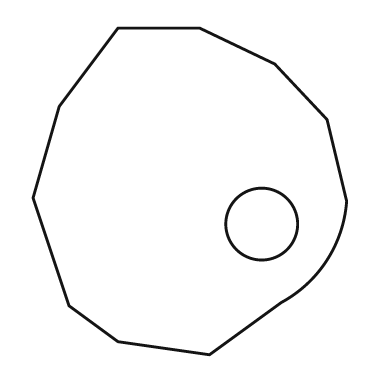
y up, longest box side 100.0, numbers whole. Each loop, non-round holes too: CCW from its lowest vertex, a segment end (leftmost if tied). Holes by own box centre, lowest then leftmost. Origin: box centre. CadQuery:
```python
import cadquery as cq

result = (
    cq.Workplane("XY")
    .moveTo(6.0, -50.0)
    .lineTo(28.0, -34.0)
    .threePointArc((42.0, -21.0), (48.0, -3.0))
    .lineTo(42.0, 22.0)
    .lineTo(26.0, 39.0)
    .lineTo(3.0, 50.0)
    .lineTo(-22.0, 50.0)
    .lineTo(-40.0, 26.0)
    .lineTo(-48.0, -2.0)
    .lineTo(-37.0, -35.0)
    .lineTo(-22.0, -46.0)
    .close()
    .moveTo(22.0, -10.0)
    .circle(11.0)
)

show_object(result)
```